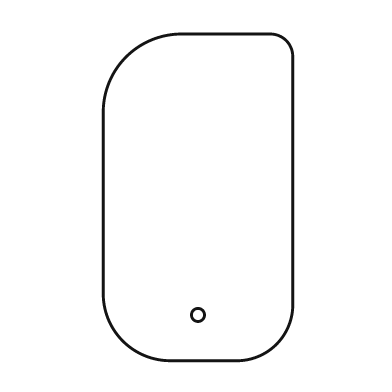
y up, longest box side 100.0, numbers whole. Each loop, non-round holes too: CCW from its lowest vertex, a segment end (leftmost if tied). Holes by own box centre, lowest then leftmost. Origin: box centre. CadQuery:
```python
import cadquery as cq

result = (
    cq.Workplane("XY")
    .moveTo(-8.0, -50.0)
    .lineTo(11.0, -50.0)
    .threePointArc((24.0, -45.0), (29.0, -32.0))
    .lineTo(29.0, 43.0)
    .threePointArc((27.0, 48.0), (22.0, 50.0))
    .lineTo(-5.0, 50.0)
    .threePointArc((-22.0, 43.0), (-29.0, 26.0))
    .lineTo(-29.0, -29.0)
    .threePointArc((-23.0, -44.0), (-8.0, -50.0))
    .close()
    .moveTo(0.0, -36.0)
    .circle(2.0)
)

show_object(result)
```